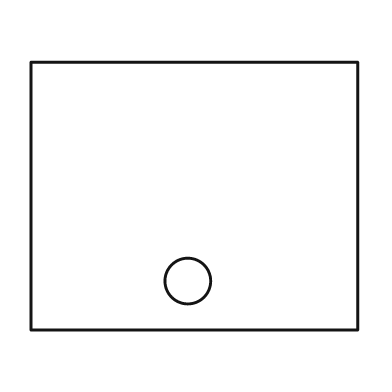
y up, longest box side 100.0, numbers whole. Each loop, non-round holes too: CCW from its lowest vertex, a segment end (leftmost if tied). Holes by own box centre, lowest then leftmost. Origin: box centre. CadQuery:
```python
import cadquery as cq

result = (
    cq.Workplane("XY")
    .moveTo(-50.0, -41.0)
    .lineTo(50.0, -41.0)
    .lineTo(50.0, 41.0)
    .lineTo(-50.0, 41.0)
    .close()
    .moveTo(-2.0, -26.0)
    .circle(7.0)
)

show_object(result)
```